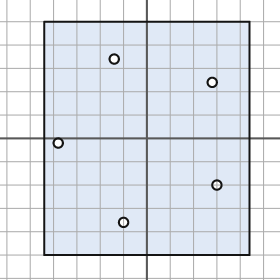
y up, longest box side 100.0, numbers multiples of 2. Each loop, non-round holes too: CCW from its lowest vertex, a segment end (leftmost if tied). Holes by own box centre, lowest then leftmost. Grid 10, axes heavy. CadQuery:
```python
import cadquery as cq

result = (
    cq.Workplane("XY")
    .moveTo(-44.0, -50.0)
    .lineTo(44.0, -50.0)
    .lineTo(44.0, 50.0)
    .lineTo(-44.0, 50.0)
    .close()
    .moveTo(-10.0, -36.0)
    .circle(2.0)
    .moveTo(30.0, -20.0)
    .circle(2.0)
    .moveTo(-38.0, -2.0)
    .circle(2.0)
    .moveTo(28.0, 24.0)
    .circle(2.0)
    .moveTo(-14.0, 34.0)
    .circle(2.0)
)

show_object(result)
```